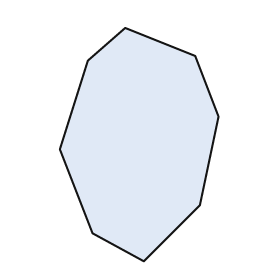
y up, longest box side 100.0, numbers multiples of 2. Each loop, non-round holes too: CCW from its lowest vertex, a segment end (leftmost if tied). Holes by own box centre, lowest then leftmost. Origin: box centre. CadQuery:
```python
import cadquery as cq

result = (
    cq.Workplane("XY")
    .moveTo(2.0, -50.0)
    .lineTo(26.0, -26.0)
    .lineTo(34.0, 12.0)
    .lineTo(24.0, 38.0)
    .lineTo(-6.0, 50.0)
    .lineTo(-22.0, 36.0)
    .lineTo(-34.0, -2.0)
    .lineTo(-20.0, -38.0)
    .close()
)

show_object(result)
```